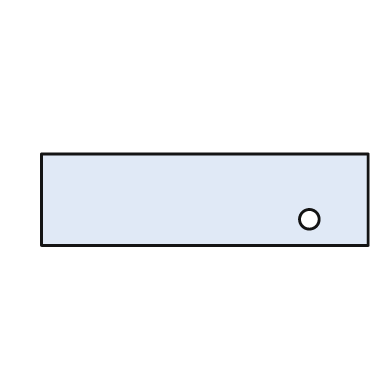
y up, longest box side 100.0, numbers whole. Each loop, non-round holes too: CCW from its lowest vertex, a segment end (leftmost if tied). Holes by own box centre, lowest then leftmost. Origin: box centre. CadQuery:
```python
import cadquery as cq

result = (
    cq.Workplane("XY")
    .moveTo(-50.0, -14.0)
    .lineTo(50.0, -14.0)
    .lineTo(50.0, 14.0)
    .lineTo(-50.0, 14.0)
    .close()
    .moveTo(32.0, -6.0)
    .circle(3.0)
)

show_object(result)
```